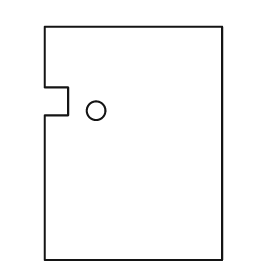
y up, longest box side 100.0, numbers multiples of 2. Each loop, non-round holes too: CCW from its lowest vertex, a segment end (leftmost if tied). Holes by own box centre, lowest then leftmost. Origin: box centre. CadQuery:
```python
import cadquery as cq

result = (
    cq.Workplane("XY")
    .moveTo(-38.0, -50.0)
    .lineTo(38.0, -50.0)
    .lineTo(38.0, 50.0)
    .lineTo(-38.0, 50.0)
    .lineTo(-38.0, 24.0)
    .lineTo(-28.0, 24.0)
    .lineTo(-28.0, 12.0)
    .lineTo(-38.0, 12.0)
    .close()
    .moveTo(-16.0, 14.0)
    .circle(4.0)
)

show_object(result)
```